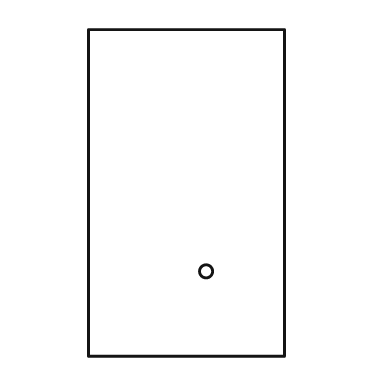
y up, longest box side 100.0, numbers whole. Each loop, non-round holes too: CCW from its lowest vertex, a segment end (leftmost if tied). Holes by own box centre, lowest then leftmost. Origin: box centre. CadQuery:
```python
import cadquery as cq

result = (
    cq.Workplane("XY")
    .moveTo(-30.0, -50.0)
    .lineTo(30.0, -50.0)
    .lineTo(30.0, 50.0)
    .lineTo(-30.0, 50.0)
    .close()
    .moveTo(6.0, -24.0)
    .circle(2.0)
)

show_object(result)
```